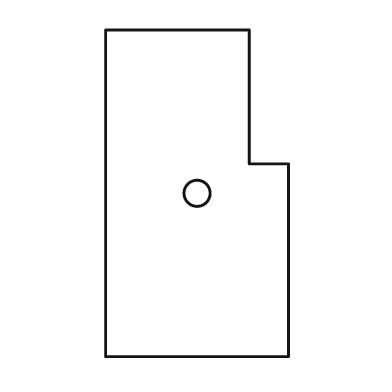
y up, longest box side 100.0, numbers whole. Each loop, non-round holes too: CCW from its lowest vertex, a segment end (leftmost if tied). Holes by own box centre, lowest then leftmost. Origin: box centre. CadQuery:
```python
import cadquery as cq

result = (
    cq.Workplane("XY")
    .moveTo(-28.0, -50.0)
    .lineTo(28.0, -50.0)
    .lineTo(28.0, 9.0)
    .lineTo(16.0, 9.0)
    .lineTo(16.0, 50.0)
    .lineTo(-28.0, 50.0)
    .close()
    .moveTo(0.0, 0.0)
    .circle(4.0)
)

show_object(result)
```